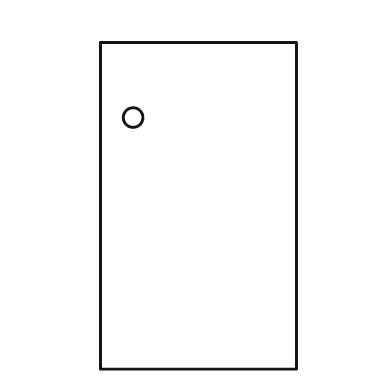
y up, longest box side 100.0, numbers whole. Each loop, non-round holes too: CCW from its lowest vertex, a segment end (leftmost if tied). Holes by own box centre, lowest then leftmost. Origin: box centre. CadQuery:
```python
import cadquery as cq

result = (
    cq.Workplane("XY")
    .moveTo(-30.0, -50.0)
    .lineTo(30.0, -50.0)
    .lineTo(30.0, 50.0)
    .lineTo(-30.0, 50.0)
    .close()
    .moveTo(-20.0, 27.0)
    .circle(3.0)
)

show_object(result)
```